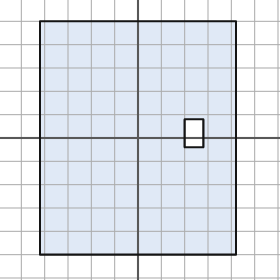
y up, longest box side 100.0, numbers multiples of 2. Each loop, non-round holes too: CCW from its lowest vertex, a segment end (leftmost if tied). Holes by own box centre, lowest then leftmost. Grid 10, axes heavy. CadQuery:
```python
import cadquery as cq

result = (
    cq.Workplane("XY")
    .moveTo(-42.0, -50.0)
    .lineTo(42.0, -50.0)
    .lineTo(42.0, 50.0)
    .lineTo(-42.0, 50.0)
    .close()
    .moveTo(20.0, -4.0)
    .lineTo(28.0, -4.0)
    .lineTo(28.0, 8.0)
    .lineTo(20.0, 8.0)
    .close()
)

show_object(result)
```